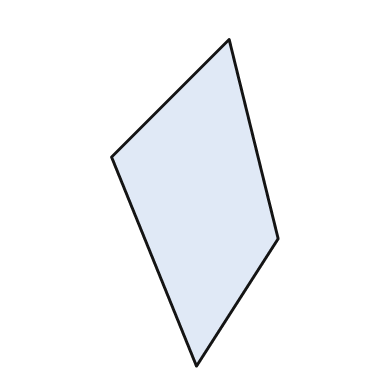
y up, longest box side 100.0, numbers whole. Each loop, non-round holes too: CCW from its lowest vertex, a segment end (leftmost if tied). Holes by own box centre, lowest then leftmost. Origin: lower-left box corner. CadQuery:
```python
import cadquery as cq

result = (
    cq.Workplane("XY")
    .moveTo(26.0, 0.0)
    .lineTo(51.0, 39.0)
    .lineTo(36.0, 100.0)
    .lineTo(0.0, 64.0)
    .close()
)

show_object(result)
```